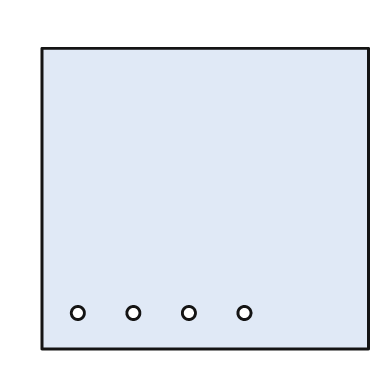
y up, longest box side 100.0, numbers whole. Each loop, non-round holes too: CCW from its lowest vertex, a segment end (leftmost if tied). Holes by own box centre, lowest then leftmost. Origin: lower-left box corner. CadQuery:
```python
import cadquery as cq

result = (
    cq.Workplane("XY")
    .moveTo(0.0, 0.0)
    .lineTo(100.0, 0.0)
    .lineTo(100.0, 92.0)
    .lineTo(0.0, 92.0)
    .close()
    .moveTo(11.0, 11.0)
    .circle(2.0)
    .moveTo(28.0, 11.0)
    .circle(2.0)
    .moveTo(45.0, 11.0)
    .circle(2.0)
    .moveTo(62.0, 11.0)
    .circle(2.0)
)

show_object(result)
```